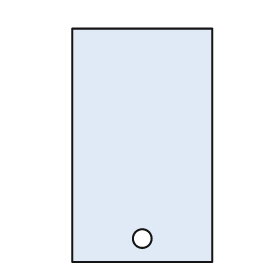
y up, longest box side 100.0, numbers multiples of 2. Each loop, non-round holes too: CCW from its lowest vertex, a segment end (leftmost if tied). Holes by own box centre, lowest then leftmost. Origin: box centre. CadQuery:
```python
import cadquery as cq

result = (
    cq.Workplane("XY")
    .moveTo(-30.0, -50.0)
    .lineTo(30.0, -50.0)
    .lineTo(30.0, 50.0)
    .lineTo(-30.0, 50.0)
    .close()
    .moveTo(0.0, -40.0)
    .circle(4.0)
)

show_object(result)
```